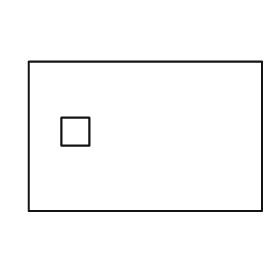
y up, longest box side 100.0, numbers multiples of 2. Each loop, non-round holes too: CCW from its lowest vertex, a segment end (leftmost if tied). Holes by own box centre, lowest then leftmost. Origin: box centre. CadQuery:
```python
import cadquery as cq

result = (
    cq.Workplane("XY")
    .moveTo(-50.0, -32.0)
    .lineTo(50.0, -32.0)
    .lineTo(50.0, 32.0)
    .lineTo(-50.0, 32.0)
    .close()
    .moveTo(-36.0, -4.0)
    .lineTo(-24.0, -4.0)
    .lineTo(-24.0, 8.0)
    .lineTo(-36.0, 8.0)
    .close()
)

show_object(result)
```